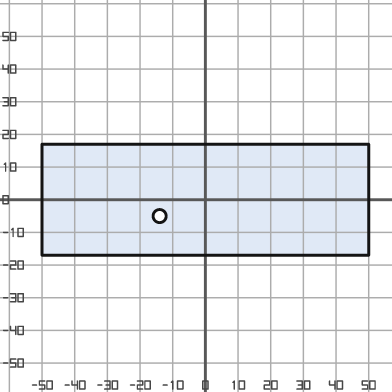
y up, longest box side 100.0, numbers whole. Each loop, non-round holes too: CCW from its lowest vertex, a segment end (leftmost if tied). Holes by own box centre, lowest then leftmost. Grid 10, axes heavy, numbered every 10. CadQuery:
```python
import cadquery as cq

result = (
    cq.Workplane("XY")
    .moveTo(-50.0, -17.0)
    .lineTo(50.0, -17.0)
    .lineTo(50.0, 17.0)
    .lineTo(-50.0, 17.0)
    .close()
    .moveTo(-14.0, -5.0)
    .circle(2.0)
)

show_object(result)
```